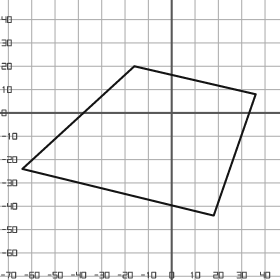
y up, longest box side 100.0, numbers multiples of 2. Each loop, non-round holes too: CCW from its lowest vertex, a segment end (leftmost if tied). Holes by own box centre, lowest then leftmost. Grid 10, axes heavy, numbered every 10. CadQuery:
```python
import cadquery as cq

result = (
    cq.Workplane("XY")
    .moveTo(18.0, -44.0)
    .lineTo(36.0, 8.0)
    .lineTo(-16.0, 20.0)
    .lineTo(-64.0, -24.0)
    .close()
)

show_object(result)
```